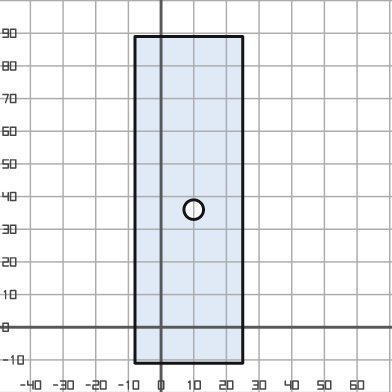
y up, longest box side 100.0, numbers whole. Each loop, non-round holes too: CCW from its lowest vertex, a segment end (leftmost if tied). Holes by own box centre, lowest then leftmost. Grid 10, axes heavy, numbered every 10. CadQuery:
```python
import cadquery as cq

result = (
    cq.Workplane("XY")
    .moveTo(-8.0, -11.0)
    .lineTo(25.0, -11.0)
    .lineTo(25.0, 89.0)
    .lineTo(-8.0, 89.0)
    .close()
    .moveTo(10.0, 36.0)
    .circle(3.0)
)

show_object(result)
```